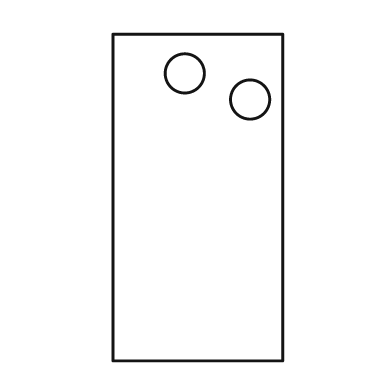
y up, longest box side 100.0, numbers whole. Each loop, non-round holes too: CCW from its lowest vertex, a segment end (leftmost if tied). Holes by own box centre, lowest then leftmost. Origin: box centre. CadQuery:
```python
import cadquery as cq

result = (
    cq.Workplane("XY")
    .moveTo(-26.0, -50.0)
    .lineTo(26.0, -50.0)
    .lineTo(26.0, 50.0)
    .lineTo(-26.0, 50.0)
    .close()
    .moveTo(16.0, 30.0)
    .circle(6.0)
    .moveTo(-4.0, 38.0)
    .circle(6.0)
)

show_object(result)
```